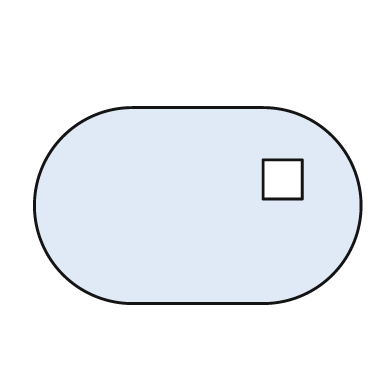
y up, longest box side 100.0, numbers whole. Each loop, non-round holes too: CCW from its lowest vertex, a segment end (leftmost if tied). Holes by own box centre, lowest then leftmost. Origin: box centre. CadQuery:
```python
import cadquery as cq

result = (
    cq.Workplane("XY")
    .moveTo(-20.0, -30.0)
    .lineTo(20.0, -30.0)
    .threePointArc((50.0, 0.0), (20.0, 30.0))
    .lineTo(-20.0, 30.0)
    .threePointArc((-50.0, 0.0), (-20.0, -30.0))
    .close()
    .moveTo(20.0, 2.0)
    .lineTo(32.0, 2.0)
    .lineTo(32.0, 14.0)
    .lineTo(20.0, 14.0)
    .close()
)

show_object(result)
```